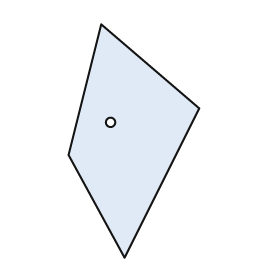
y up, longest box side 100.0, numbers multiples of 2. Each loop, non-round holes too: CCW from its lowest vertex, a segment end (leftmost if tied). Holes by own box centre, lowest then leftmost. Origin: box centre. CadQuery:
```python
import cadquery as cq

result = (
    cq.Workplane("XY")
    .moveTo(-4.0, -50.0)
    .lineTo(28.0, 14.0)
    .lineTo(-14.0, 50.0)
    .lineTo(-28.0, -6.0)
    .close()
    .moveTo(-10.0, 8.0)
    .circle(2.0)
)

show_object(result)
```